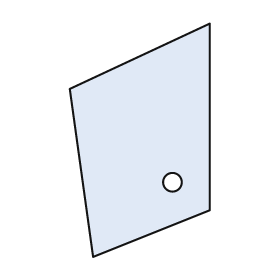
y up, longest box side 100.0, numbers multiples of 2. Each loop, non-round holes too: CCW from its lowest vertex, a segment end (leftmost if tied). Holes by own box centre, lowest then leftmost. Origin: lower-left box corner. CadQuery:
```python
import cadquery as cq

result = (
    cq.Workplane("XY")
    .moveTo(10.0, 0.0)
    .lineTo(60.0, 20.0)
    .lineTo(60.0, 100.0)
    .lineTo(0.0, 72.0)
    .close()
    .moveTo(44.0, 32.0)
    .circle(4.0)
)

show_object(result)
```